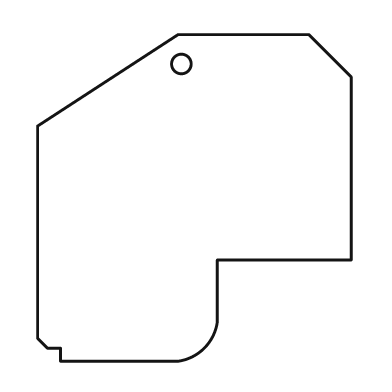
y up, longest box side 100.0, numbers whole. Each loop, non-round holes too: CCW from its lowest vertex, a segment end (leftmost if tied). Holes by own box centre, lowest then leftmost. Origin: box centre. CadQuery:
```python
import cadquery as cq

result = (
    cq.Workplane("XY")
    .moveTo(-41.0, -50.0)
    .lineTo(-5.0, -50.0)
    .threePointArc((3.0, -46.0), (7.0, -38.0))
    .lineTo(7.0, -19.0)
    .lineTo(48.0, -19.0)
    .lineTo(48.0, 37.0)
    .lineTo(35.0, 50.0)
    .lineTo(-5.0, 50.0)
    .lineTo(-48.0, 22.0)
    .lineTo(-48.0, -43.0)
    .lineTo(-45.0, -46.0)
    .lineTo(-41.0, -46.0)
    .close()
    .moveTo(-4.0, 41.0)
    .circle(3.0)
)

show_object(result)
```